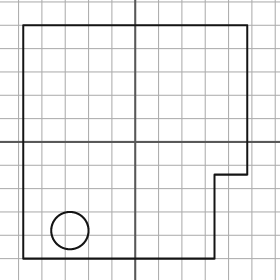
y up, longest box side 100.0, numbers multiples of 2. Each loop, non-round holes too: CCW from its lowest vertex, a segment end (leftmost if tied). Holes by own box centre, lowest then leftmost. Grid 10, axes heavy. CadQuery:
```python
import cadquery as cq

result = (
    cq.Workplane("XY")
    .moveTo(-48.0, -50.0)
    .lineTo(34.0, -50.0)
    .lineTo(34.0, -14.0)
    .lineTo(48.0, -14.0)
    .lineTo(48.0, 50.0)
    .lineTo(-48.0, 50.0)
    .close()
    .moveTo(-28.0, -38.0)
    .circle(8.0)
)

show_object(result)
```